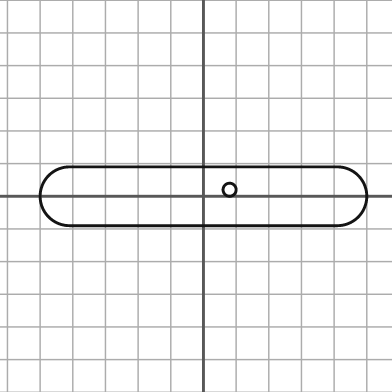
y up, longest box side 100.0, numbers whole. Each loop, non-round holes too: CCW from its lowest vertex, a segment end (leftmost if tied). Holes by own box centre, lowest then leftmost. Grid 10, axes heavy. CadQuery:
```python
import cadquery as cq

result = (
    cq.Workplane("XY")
    .moveTo(-41.0, -9.0)
    .lineTo(41.0, -9.0)
    .threePointArc((50.0, 0.0), (41.0, 9.0))
    .lineTo(-41.0, 9.0)
    .threePointArc((-50.0, 0.0), (-41.0, -9.0))
    .close()
    .moveTo(8.0, 2.0)
    .circle(2.0)
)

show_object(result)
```